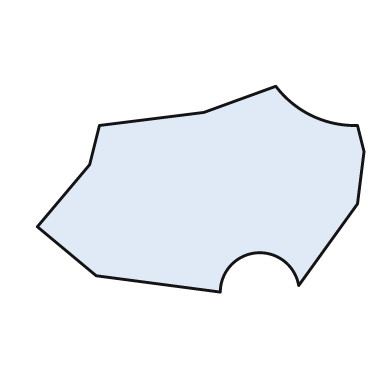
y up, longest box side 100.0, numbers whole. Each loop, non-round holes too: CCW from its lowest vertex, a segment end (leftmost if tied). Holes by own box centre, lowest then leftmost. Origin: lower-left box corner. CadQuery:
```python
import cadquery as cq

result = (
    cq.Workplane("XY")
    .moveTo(56.0, 0.0)
    .threePointArc((67.0, 12.0), (80.0, 2.0))
    .lineTo(98.0, 27.0)
    .lineTo(100.0, 43.0)
    .lineTo(98.0, 51.0)
    .threePointArc((84.0, 54.0), (73.0, 63.0))
    .lineTo(51.0, 55.0)
    .lineTo(19.0, 51.0)
    .lineTo(16.0, 39.0)
    .lineTo(0.0, 20.0)
    .lineTo(18.0, 5.0)
    .close()
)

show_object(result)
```